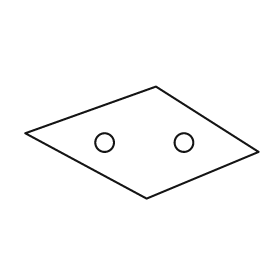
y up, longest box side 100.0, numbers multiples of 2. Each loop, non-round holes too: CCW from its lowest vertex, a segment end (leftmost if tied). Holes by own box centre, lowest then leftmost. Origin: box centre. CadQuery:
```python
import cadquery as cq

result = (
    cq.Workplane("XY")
    .moveTo(2.0, -24.0)
    .lineTo(50.0, -4.0)
    .lineTo(6.0, 24.0)
    .lineTo(-50.0, 4.0)
    .close()
    .moveTo(-16.0, 0.0)
    .circle(4.0)
    .moveTo(18.0, 0.0)
    .circle(4.0)
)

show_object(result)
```